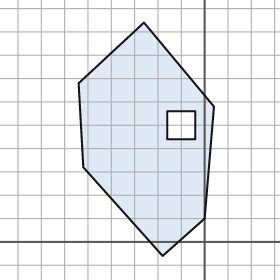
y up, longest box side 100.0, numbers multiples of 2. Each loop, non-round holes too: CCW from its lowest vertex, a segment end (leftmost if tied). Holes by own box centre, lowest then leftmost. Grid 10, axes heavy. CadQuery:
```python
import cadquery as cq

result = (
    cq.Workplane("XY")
    .moveTo(-18.0, -6.0)
    .lineTo(0.0, 10.0)
    .lineTo(4.0, 58.0)
    .lineTo(-26.0, 94.0)
    .lineTo(-54.0, 68.0)
    .lineTo(-52.0, 32.0)
    .close()
    .moveTo(-16.0, 44.0)
    .lineTo(-4.0, 44.0)
    .lineTo(-4.0, 56.0)
    .lineTo(-16.0, 56.0)
    .close()
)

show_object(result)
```